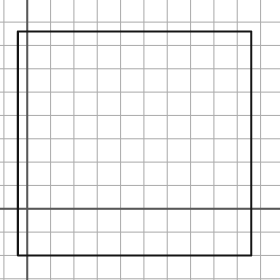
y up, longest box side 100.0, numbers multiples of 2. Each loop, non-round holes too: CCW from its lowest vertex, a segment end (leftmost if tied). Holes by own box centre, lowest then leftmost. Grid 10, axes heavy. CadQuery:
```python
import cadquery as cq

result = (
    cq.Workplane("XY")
    .moveTo(-4.0, -20.0)
    .lineTo(96.0, -20.0)
    .lineTo(96.0, 76.0)
    .lineTo(-4.0, 76.0)
    .close()
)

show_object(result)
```